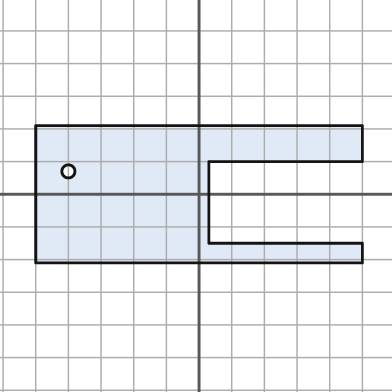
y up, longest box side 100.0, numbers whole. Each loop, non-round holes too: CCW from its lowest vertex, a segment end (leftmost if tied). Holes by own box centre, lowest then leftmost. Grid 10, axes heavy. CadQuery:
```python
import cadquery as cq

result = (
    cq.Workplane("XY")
    .moveTo(-50.0, -21.0)
    .lineTo(50.0, -21.0)
    .lineTo(50.0, -15.0)
    .lineTo(3.0, -15.0)
    .lineTo(3.0, 10.0)
    .lineTo(50.0, 10.0)
    .lineTo(50.0, 21.0)
    .lineTo(-50.0, 21.0)
    .close()
    .moveTo(-40.0, 7.0)
    .circle(2.0)
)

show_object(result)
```